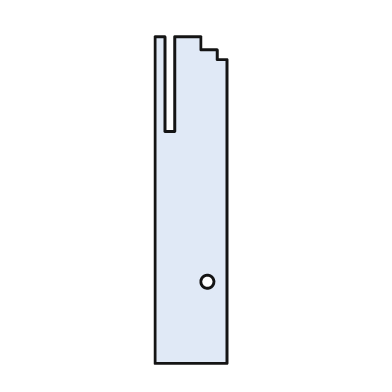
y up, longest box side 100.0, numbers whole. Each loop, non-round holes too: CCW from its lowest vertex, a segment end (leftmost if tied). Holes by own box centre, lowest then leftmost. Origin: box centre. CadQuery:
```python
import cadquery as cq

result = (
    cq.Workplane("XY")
    .moveTo(-11.0, -50.0)
    .lineTo(11.0, -50.0)
    .lineTo(11.0, 43.0)
    .lineTo(8.0, 43.0)
    .lineTo(8.0, 46.0)
    .lineTo(3.0, 46.0)
    .lineTo(3.0, 50.0)
    .lineTo(-5.0, 50.0)
    .lineTo(-5.0, 21.0)
    .lineTo(-8.0, 21.0)
    .lineTo(-8.0, 50.0)
    .lineTo(-11.0, 50.0)
    .close()
    .moveTo(5.0, -25.0)
    .circle(2.0)
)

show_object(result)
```